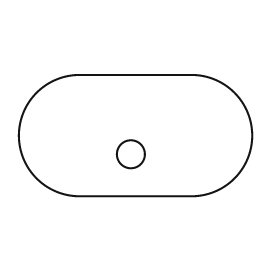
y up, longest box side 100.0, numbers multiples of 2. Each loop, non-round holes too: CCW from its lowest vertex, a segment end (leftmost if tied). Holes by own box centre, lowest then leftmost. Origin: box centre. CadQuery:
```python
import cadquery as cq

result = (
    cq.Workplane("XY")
    .moveTo(-24.0, -26.0)
    .lineTo(24.0, -26.0)
    .threePointArc((50.0, 0.0), (24.0, 26.0))
    .lineTo(-24.0, 26.0)
    .threePointArc((-50.0, 0.0), (-24.0, -26.0))
    .close()
    .moveTo(-2.0, -8.0)
    .circle(6.0)
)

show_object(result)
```